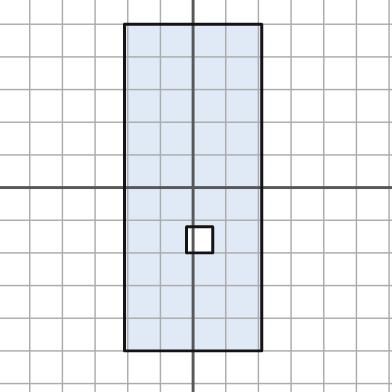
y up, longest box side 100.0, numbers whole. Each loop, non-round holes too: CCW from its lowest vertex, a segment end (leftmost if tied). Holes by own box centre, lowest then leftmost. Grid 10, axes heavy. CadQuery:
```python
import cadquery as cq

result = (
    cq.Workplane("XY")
    .moveTo(-21.0, -50.0)
    .lineTo(21.0, -50.0)
    .lineTo(21.0, 50.0)
    .lineTo(-21.0, 50.0)
    .close()
    .moveTo(-2.0, -20.0)
    .lineTo(6.0, -20.0)
    .lineTo(6.0, -12.0)
    .lineTo(-2.0, -12.0)
    .close()
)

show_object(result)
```